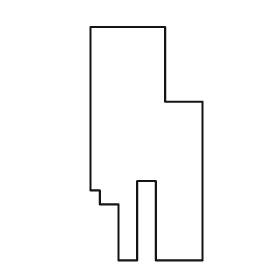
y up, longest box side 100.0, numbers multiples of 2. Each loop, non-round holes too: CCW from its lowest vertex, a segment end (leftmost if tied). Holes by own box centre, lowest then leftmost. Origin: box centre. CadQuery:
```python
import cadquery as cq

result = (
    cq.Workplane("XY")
    .moveTo(-12.0, -50.0)
    .lineTo(-4.0, -50.0)
    .lineTo(-4.0, -16.0)
    .lineTo(4.0, -16.0)
    .lineTo(4.0, -50.0)
    .lineTo(24.0, -50.0)
    .lineTo(24.0, 18.0)
    .lineTo(8.0, 18.0)
    .lineTo(8.0, 50.0)
    .lineTo(-24.0, 50.0)
    .lineTo(-24.0, -20.0)
    .lineTo(-20.0, -20.0)
    .lineTo(-20.0, -26.0)
    .lineTo(-12.0, -26.0)
    .close()
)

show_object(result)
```